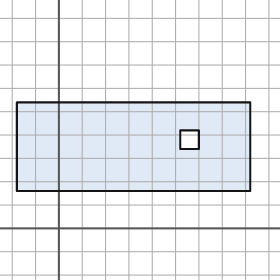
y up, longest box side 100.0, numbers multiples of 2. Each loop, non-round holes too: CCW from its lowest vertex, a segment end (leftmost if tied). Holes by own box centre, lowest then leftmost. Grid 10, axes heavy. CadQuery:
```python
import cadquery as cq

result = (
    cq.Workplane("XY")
    .moveTo(-18.0, 16.0)
    .lineTo(82.0, 16.0)
    .lineTo(82.0, 54.0)
    .lineTo(-18.0, 54.0)
    .close()
    .moveTo(52.0, 34.0)
    .lineTo(60.0, 34.0)
    .lineTo(60.0, 42.0)
    .lineTo(52.0, 42.0)
    .close()
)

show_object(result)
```